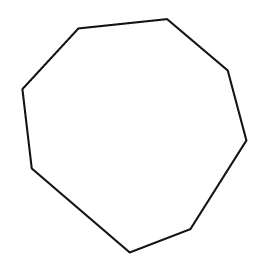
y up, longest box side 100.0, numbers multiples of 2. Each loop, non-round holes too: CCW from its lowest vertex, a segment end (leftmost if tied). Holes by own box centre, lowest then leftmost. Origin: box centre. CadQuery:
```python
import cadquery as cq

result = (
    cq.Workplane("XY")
    .moveTo(-2.0, -50.0)
    .lineTo(24.0, -40.0)
    .lineTo(48.0, -2.0)
    .lineTo(40.0, 28.0)
    .lineTo(14.0, 50.0)
    .lineTo(-24.0, 46.0)
    .lineTo(-48.0, 20.0)
    .lineTo(-44.0, -14.0)
    .close()
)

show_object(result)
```